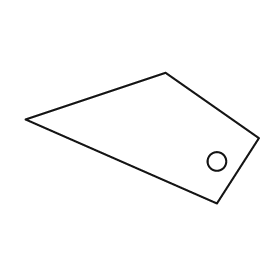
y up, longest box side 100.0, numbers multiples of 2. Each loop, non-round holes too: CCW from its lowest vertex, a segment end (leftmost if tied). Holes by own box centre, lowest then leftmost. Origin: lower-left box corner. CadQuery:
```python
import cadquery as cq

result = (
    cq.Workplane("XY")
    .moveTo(82.0, 0.0)
    .lineTo(100.0, 28.0)
    .lineTo(60.0, 56.0)
    .lineTo(0.0, 36.0)
    .close()
    .moveTo(82.0, 18.0)
    .circle(4.0)
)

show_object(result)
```